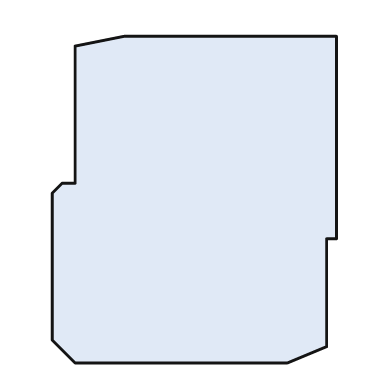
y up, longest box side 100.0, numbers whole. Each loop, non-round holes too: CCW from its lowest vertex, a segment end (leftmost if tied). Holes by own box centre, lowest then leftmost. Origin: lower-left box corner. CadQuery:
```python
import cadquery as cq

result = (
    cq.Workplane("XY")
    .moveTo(7.0, 0.0)
    .lineTo(72.0, 0.0)
    .lineTo(84.0, 5.0)
    .lineTo(84.0, 38.0)
    .lineTo(87.0, 38.0)
    .lineTo(87.0, 100.0)
    .lineTo(22.0, 100.0)
    .lineTo(7.0, 97.0)
    .lineTo(7.0, 55.0)
    .lineTo(3.0, 55.0)
    .lineTo(0.0, 52.0)
    .lineTo(0.0, 7.0)
    .close()
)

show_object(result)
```